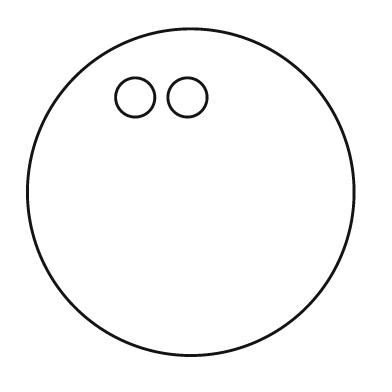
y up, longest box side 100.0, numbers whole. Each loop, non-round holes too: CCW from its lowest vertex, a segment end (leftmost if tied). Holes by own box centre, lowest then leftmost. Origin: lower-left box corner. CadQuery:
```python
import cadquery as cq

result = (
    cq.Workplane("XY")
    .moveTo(50.0, 50.0)
    .circle(50.0)
    .moveTo(33.0, 79.0)
    .circle(6.0)
    .moveTo(49.0, 79.0)
    .circle(6.0)
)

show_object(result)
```